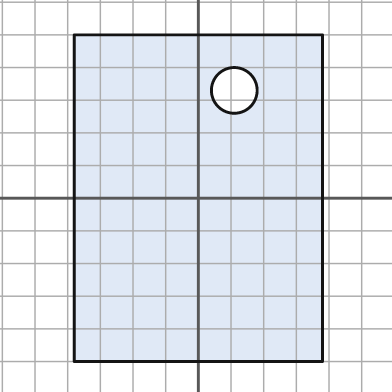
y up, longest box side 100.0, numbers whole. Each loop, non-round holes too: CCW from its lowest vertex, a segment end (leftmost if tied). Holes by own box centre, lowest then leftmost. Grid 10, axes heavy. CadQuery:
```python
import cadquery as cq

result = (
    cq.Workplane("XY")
    .moveTo(-38.0, -50.0)
    .lineTo(38.0, -50.0)
    .lineTo(38.0, 50.0)
    .lineTo(-38.0, 50.0)
    .close()
    .moveTo(11.0, 33.0)
    .circle(7.0)
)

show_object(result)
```